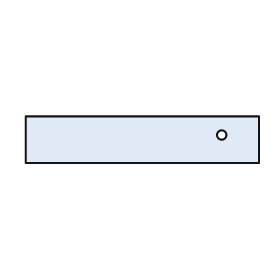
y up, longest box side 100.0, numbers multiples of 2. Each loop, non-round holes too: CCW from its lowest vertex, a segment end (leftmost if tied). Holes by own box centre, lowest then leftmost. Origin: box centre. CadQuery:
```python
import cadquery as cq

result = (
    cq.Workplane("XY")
    .moveTo(-50.0, -10.0)
    .lineTo(50.0, -10.0)
    .lineTo(50.0, 10.0)
    .lineTo(-50.0, 10.0)
    .close()
    .moveTo(34.0, 2.0)
    .circle(2.0)
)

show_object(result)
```